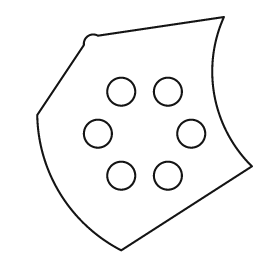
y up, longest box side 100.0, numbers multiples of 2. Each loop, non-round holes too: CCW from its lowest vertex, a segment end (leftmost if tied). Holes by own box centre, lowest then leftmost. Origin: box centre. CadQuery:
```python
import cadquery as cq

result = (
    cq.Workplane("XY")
    .moveTo(-10.0, -50.0)
    .lineTo(46.0, -14.0)
    .threePointArc((30.0, 16.0), (34.0, 50.0))
    .lineTo(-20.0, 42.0)
    .threePointArc((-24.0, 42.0), (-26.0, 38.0))
    .lineTo(-46.0, 8.0)
    .threePointArc((-36.0, -26.0), (-10.0, -50.0))
    .close()
    .moveTo(-10.0, -18.0)
    .circle(6.0)
    .moveTo(10.0, -18.0)
    .circle(6.0)
    .moveTo(-20.0, 0.0)
    .circle(6.0)
    .moveTo(20.0, 0.0)
    .circle(6.0)
    .moveTo(-10.0, 18.0)
    .circle(6.0)
    .moveTo(10.0, 18.0)
    .circle(6.0)
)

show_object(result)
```